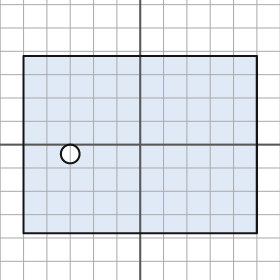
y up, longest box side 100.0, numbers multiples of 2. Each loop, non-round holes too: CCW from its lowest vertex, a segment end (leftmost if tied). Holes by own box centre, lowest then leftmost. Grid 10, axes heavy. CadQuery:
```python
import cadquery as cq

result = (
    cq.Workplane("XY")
    .moveTo(-50.0, -38.0)
    .lineTo(50.0, -38.0)
    .lineTo(50.0, 38.0)
    .lineTo(-50.0, 38.0)
    .close()
    .moveTo(-30.0, -4.0)
    .circle(4.0)
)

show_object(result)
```